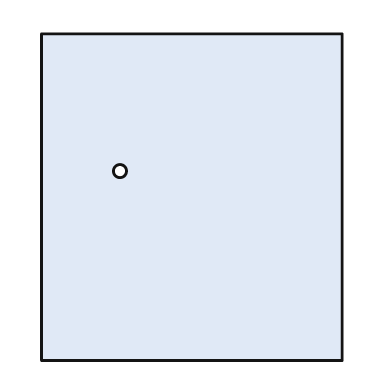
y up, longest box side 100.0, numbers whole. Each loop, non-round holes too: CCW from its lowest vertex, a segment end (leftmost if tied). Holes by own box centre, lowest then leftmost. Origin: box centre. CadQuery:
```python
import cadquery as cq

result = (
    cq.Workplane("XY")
    .moveTo(-46.0, -50.0)
    .lineTo(46.0, -50.0)
    .lineTo(46.0, 50.0)
    .lineTo(-46.0, 50.0)
    .close()
    .moveTo(-22.0, 8.0)
    .circle(2.0)
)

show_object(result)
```